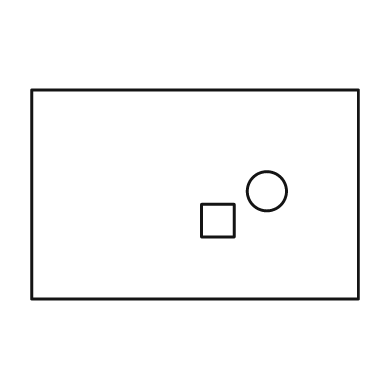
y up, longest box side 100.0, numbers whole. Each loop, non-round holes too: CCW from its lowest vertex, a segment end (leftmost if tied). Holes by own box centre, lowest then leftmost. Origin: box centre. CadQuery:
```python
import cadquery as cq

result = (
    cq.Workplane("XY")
    .moveTo(-50.0, -32.0)
    .lineTo(50.0, -32.0)
    .lineTo(50.0, 32.0)
    .lineTo(-50.0, 32.0)
    .close()
    .moveTo(2.0, -13.0)
    .lineTo(12.0, -13.0)
    .lineTo(12.0, -3.0)
    .lineTo(2.0, -3.0)
    .close()
    .moveTo(22.0, 1.0)
    .circle(6.0)
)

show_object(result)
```